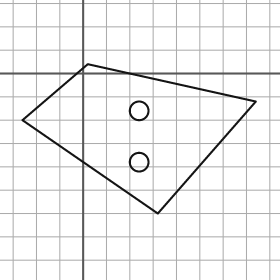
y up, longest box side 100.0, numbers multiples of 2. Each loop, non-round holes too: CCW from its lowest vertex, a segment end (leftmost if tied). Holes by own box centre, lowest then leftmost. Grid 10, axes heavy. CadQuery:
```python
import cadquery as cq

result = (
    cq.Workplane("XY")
    .moveTo(32.0, -60.0)
    .lineTo(74.0, -12.0)
    .lineTo(2.0, 4.0)
    .lineTo(-26.0, -20.0)
    .close()
    .moveTo(24.0, -38.0)
    .circle(4.0)
    .moveTo(24.0, -16.0)
    .circle(4.0)
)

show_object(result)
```